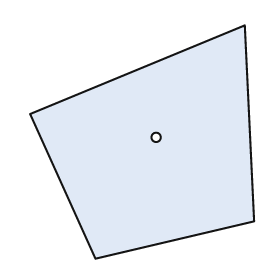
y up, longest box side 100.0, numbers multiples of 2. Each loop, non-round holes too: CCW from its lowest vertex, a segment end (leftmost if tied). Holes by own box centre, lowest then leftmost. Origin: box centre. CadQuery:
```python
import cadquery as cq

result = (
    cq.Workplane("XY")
    .moveTo(-20.0, -50.0)
    .lineTo(48.0, -34.0)
    .lineTo(44.0, 50.0)
    .lineTo(-48.0, 12.0)
    .close()
    .moveTo(6.0, 2.0)
    .circle(2.0)
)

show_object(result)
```